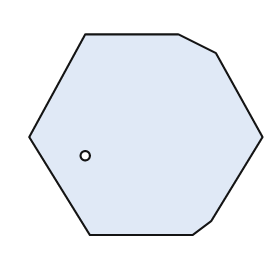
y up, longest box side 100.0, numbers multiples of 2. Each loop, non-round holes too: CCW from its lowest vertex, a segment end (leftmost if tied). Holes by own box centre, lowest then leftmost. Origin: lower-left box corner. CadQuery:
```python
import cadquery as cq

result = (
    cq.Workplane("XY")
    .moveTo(26.0, 0.0)
    .lineTo(70.0, 0.0)
    .lineTo(78.0, 6.0)
    .lineTo(100.0, 42.0)
    .lineTo(80.0, 78.0)
    .lineTo(64.0, 86.0)
    .lineTo(24.0, 86.0)
    .lineTo(0.0, 42.0)
    .close()
    .moveTo(24.0, 34.0)
    .circle(2.0)
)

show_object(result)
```